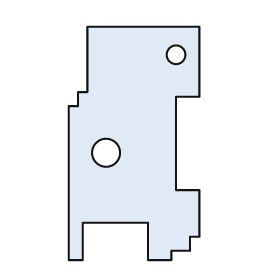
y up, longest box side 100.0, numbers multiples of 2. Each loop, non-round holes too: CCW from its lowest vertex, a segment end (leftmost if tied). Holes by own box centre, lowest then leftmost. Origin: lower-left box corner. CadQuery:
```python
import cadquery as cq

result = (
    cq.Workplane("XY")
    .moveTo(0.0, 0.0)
    .lineTo(6.0, 0.0)
    .lineTo(6.0, 16.0)
    .lineTo(34.0, 16.0)
    .lineTo(34.0, 0.0)
    .lineTo(44.0, 0.0)
    .lineTo(44.0, 4.0)
    .lineTo(52.0, 4.0)
    .lineTo(52.0, 10.0)
    .lineTo(56.0, 10.0)
    .lineTo(56.0, 30.0)
    .lineTo(46.0, 30.0)
    .lineTo(46.0, 70.0)
    .lineTo(56.0, 70.0)
    .lineTo(56.0, 100.0)
    .lineTo(8.0, 100.0)
    .lineTo(8.0, 72.0)
    .lineTo(4.0, 72.0)
    .lineTo(4.0, 66.0)
    .lineTo(0.0, 66.0)
    .close()
    .moveTo(16.0, 46.0)
    .circle(6.0)
    .moveTo(46.0, 88.0)
    .circle(4.0)
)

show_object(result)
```